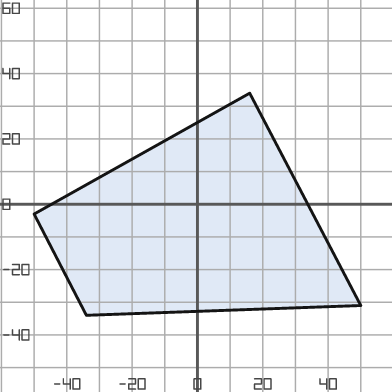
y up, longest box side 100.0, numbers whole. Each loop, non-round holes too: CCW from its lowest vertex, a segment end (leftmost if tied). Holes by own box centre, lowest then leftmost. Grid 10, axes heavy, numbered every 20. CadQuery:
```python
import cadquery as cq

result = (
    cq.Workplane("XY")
    .moveTo(-34.0, -34.0)
    .lineTo(50.0, -31.0)
    .lineTo(16.0, 34.0)
    .lineTo(-50.0, -3.0)
    .close()
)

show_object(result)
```